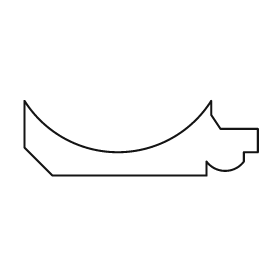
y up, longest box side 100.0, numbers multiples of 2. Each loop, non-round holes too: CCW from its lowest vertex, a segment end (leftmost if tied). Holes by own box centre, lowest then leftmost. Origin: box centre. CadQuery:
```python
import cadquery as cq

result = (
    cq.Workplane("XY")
    .moveTo(-38.0, -16.0)
    .lineTo(28.0, -16.0)
    .lineTo(28.0, -10.0)
    .threePointArc((36.0, -14.0), (44.0, -10.0))
    .lineTo(44.0, -6.0)
    .lineTo(50.0, -6.0)
    .lineTo(50.0, 4.0)
    .lineTo(34.0, 4.0)
    .lineTo(30.0, 10.0)
    .lineTo(30.0, 16.0)
    .threePointArc((-10.0, -6.0), (-50.0, 16.0))
    .lineTo(-50.0, -4.0)
    .close()
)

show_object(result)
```